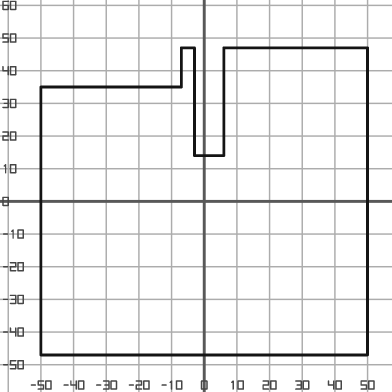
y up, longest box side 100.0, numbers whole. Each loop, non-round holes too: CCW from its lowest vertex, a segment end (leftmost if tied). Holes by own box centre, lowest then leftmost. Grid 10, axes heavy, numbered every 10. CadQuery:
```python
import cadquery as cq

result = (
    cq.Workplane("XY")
    .moveTo(-50.0, -47.0)
    .lineTo(50.0, -47.0)
    .lineTo(50.0, 47.0)
    .lineTo(6.0, 47.0)
    .lineTo(6.0, 14.0)
    .lineTo(-3.0, 14.0)
    .lineTo(-3.0, 47.0)
    .lineTo(-7.0, 47.0)
    .lineTo(-7.0, 35.0)
    .lineTo(-50.0, 35.0)
    .close()
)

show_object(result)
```